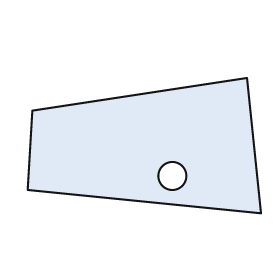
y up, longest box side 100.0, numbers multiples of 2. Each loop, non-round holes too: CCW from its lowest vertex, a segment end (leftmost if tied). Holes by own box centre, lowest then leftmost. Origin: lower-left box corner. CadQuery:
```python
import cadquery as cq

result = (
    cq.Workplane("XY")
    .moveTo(100.0, 0.0)
    .lineTo(94.0, 58.0)
    .lineTo(2.0, 44.0)
    .lineTo(0.0, 10.0)
    .close()
    .moveTo(62.0, 16.0)
    .circle(6.0)
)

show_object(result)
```